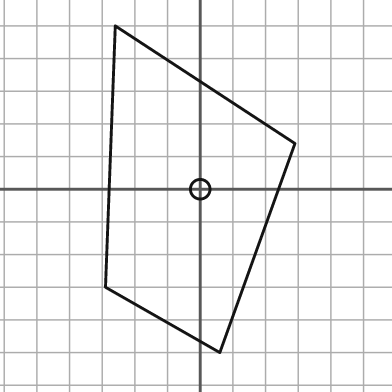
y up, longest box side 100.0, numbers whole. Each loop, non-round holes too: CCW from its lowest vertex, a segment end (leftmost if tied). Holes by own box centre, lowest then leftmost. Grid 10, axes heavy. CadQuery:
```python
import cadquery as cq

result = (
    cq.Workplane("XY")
    .moveTo(6.0, -50.0)
    .lineTo(29.0, 14.0)
    .lineTo(-26.0, 50.0)
    .lineTo(-29.0, -30.0)
    .close()
    .moveTo(0.0, 0.0)
    .circle(3.0)
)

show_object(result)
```